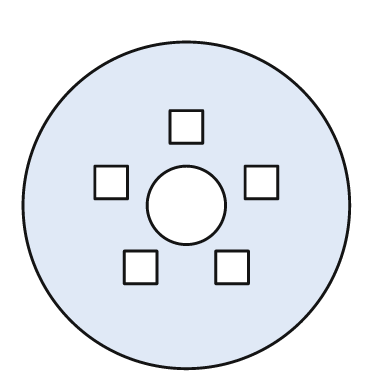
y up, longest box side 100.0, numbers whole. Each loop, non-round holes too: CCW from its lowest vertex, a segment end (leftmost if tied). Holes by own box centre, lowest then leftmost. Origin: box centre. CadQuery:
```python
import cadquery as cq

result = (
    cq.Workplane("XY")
    .moveTo(0.0, 0.0)
    .circle(50.0)
    .moveTo(-19.0, -24.0)
    .lineTo(-9.0, -24.0)
    .lineTo(-9.0, -14.0)
    .lineTo(-19.0, -14.0)
    .close()
    .moveTo(9.0, -24.0)
    .lineTo(19.0, -24.0)
    .lineTo(19.0, -14.0)
    .lineTo(9.0, -14.0)
    .close()
    .moveTo(0.0, 0.0)
    .circle(12.0)
    .moveTo(-28.0, 2.0)
    .lineTo(-18.0, 2.0)
    .lineTo(-18.0, 12.0)
    .lineTo(-28.0, 12.0)
    .close()
    .moveTo(18.0, 2.0)
    .lineTo(28.0, 2.0)
    .lineTo(28.0, 12.0)
    .lineTo(18.0, 12.0)
    .close()
    .moveTo(-5.0, 19.0)
    .lineTo(5.0, 19.0)
    .lineTo(5.0, 29.0)
    .lineTo(-5.0, 29.0)
    .close()
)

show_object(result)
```